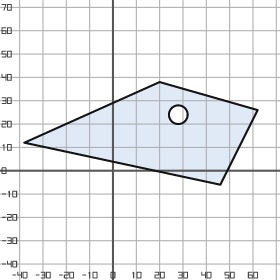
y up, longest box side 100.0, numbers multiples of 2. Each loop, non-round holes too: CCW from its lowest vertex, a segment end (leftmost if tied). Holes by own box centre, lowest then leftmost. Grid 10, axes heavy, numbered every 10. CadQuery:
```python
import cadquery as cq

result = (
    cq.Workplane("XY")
    .moveTo(46.0, -6.0)
    .lineTo(62.0, 26.0)
    .lineTo(20.0, 38.0)
    .lineTo(-38.0, 12.0)
    .close()
    .moveTo(28.0, 24.0)
    .circle(4.0)
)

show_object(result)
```